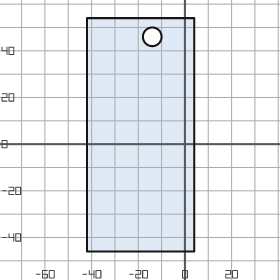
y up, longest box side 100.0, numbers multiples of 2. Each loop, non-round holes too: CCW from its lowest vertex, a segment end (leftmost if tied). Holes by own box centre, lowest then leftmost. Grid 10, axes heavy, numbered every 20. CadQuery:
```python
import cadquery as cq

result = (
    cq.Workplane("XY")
    .moveTo(-42.0, -46.0)
    .lineTo(4.0, -46.0)
    .lineTo(4.0, 54.0)
    .lineTo(-42.0, 54.0)
    .close()
    .moveTo(-14.0, 46.0)
    .circle(4.0)
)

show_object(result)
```